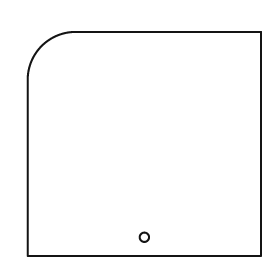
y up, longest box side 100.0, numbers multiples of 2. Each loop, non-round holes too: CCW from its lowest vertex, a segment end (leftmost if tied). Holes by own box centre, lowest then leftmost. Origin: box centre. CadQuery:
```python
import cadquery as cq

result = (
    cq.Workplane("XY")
    .moveTo(-50.0, -48.0)
    .lineTo(50.0, -48.0)
    .lineTo(50.0, 48.0)
    .lineTo(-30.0, 48.0)
    .threePointArc((-44.0, 42.0), (-50.0, 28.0))
    .close()
    .moveTo(0.0, -40.0)
    .circle(2.0)
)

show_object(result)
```